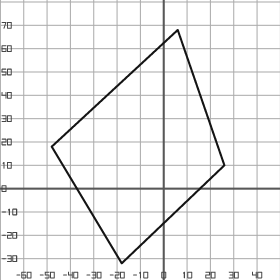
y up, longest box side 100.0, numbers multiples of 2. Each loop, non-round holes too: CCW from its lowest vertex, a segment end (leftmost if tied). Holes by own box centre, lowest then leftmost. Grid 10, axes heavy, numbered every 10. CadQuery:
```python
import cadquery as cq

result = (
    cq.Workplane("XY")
    .moveTo(-18.0, -32.0)
    .lineTo(26.0, 10.0)
    .lineTo(6.0, 68.0)
    .lineTo(-48.0, 18.0)
    .close()
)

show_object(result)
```